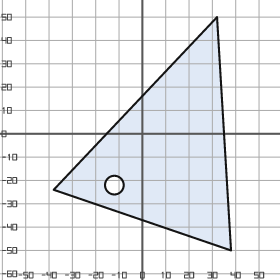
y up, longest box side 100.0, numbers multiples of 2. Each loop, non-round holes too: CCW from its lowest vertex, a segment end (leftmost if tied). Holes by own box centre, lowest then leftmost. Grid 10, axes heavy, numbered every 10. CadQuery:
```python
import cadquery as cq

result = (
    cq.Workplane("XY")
    .moveTo(38.0, -50.0)
    .lineTo(32.0, 50.0)
    .lineTo(-38.0, -24.0)
    .close()
    .moveTo(-12.0, -22.0)
    .circle(4.0)
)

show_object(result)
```